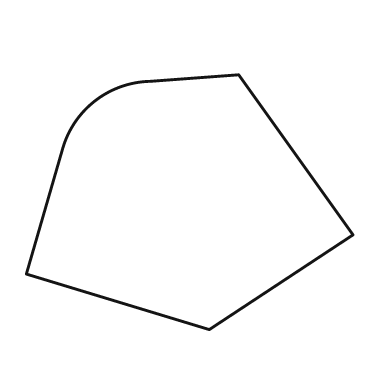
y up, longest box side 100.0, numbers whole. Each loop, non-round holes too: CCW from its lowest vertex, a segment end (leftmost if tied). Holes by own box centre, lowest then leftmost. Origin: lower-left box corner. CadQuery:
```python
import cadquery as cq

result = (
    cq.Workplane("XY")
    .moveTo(56.0, 0.0)
    .lineTo(100.0, 29.0)
    .lineTo(65.0, 78.0)
    .lineTo(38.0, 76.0)
    .threePointArc((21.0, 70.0), (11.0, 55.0))
    .lineTo(0.0, 17.0)
    .close()
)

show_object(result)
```